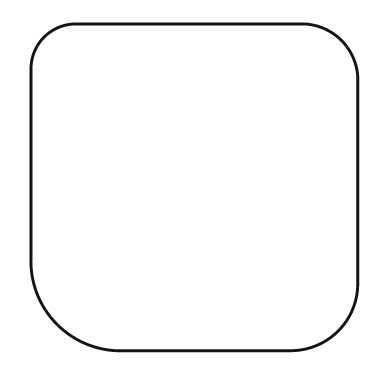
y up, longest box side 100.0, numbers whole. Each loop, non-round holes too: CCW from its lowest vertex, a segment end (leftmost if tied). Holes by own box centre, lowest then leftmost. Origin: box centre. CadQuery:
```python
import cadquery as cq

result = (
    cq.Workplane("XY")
    .moveTo(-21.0, -50.0)
    .lineTo(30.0, -50.0)
    .threePointArc((44.0, -44.0), (50.0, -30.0))
    .lineTo(50.0, 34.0)
    .threePointArc((45.0, 45.0), (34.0, 50.0))
    .lineTo(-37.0, 50.0)
    .threePointArc((-46.0, 46.0), (-50.0, 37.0))
    .lineTo(-50.0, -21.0)
    .threePointArc((-42.0, -42.0), (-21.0, -50.0))
    .close()
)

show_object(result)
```